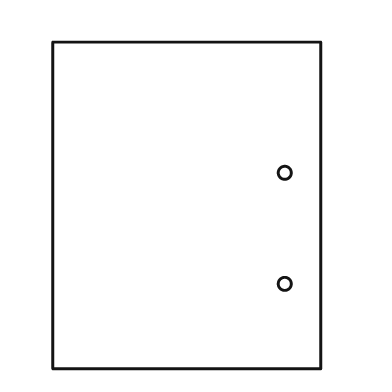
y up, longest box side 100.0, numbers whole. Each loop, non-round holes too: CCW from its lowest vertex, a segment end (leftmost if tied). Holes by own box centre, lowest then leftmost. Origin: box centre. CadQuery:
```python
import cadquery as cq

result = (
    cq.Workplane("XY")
    .moveTo(-41.0, -50.0)
    .lineTo(41.0, -50.0)
    .lineTo(41.0, 50.0)
    .lineTo(-41.0, 50.0)
    .close()
    .moveTo(30.0, -24.0)
    .circle(2.0)
    .moveTo(30.0, 10.0)
    .circle(2.0)
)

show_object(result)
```